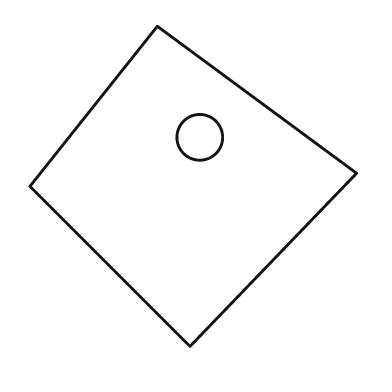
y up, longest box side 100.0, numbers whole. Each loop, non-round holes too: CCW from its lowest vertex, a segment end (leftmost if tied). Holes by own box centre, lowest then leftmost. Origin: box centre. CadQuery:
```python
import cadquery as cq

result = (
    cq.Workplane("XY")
    .moveTo(-1.0, -49.0)
    .lineTo(50.0, 4.0)
    .lineTo(-11.0, 49.0)
    .lineTo(-50.0, 0.0)
    .close()
    .moveTo(2.0, 15.0)
    .circle(7.0)
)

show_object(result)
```